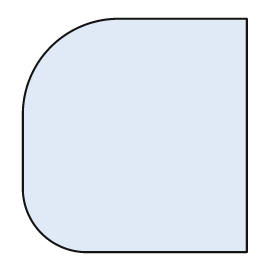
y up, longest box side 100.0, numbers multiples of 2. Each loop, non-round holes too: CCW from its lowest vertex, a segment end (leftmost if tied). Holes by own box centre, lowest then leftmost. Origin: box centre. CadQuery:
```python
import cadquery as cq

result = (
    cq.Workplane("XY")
    .moveTo(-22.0, -50.0)
    .lineTo(48.0, -50.0)
    .lineTo(48.0, 50.0)
    .lineTo(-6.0, 50.0)
    .threePointArc((-36.0, 38.0), (-48.0, 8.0))
    .lineTo(-48.0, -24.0)
    .threePointArc((-40.0, -42.0), (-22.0, -50.0))
    .close()
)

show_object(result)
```